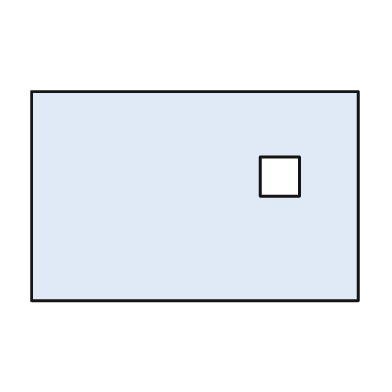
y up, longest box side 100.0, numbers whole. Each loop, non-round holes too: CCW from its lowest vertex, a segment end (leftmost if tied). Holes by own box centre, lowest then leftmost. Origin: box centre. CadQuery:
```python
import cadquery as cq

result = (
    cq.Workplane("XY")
    .moveTo(-50.0, -32.0)
    .lineTo(50.0, -32.0)
    .lineTo(50.0, 32.0)
    .lineTo(-50.0, 32.0)
    .close()
    .moveTo(20.0, 0.0)
    .lineTo(32.0, 0.0)
    .lineTo(32.0, 12.0)
    .lineTo(20.0, 12.0)
    .close()
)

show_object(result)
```